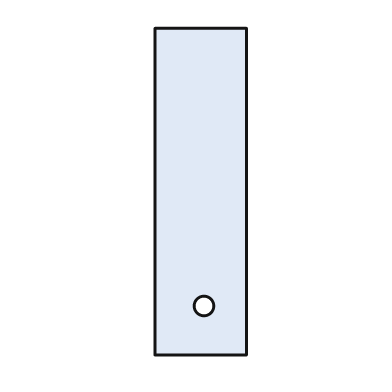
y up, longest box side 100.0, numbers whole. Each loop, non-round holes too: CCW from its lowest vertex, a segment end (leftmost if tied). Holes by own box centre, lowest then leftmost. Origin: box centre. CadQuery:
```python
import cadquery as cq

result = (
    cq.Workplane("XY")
    .moveTo(-14.0, -50.0)
    .lineTo(14.0, -50.0)
    .lineTo(14.0, 50.0)
    .lineTo(-14.0, 50.0)
    .close()
    .moveTo(1.0, -35.0)
    .circle(3.0)
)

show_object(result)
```